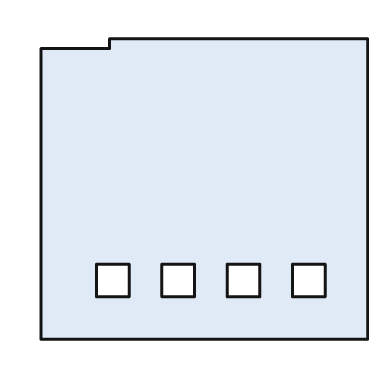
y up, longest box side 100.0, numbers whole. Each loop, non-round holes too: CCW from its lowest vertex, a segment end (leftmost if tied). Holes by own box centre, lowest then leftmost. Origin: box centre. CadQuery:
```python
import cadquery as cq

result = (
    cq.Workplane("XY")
    .moveTo(-50.0, -46.0)
    .lineTo(50.0, -46.0)
    .lineTo(50.0, 46.0)
    .lineTo(-29.0, 46.0)
    .lineTo(-29.0, 43.0)
    .lineTo(-50.0, 43.0)
    .close()
    .moveTo(-33.0, -33.0)
    .lineTo(-23.0, -33.0)
    .lineTo(-23.0, -23.0)
    .lineTo(-33.0, -23.0)
    .close()
    .moveTo(-13.0, -33.0)
    .lineTo(-3.0, -33.0)
    .lineTo(-3.0, -23.0)
    .lineTo(-13.0, -23.0)
    .close()
    .moveTo(7.0, -33.0)
    .lineTo(17.0, -33.0)
    .lineTo(17.0, -23.0)
    .lineTo(7.0, -23.0)
    .close()
    .moveTo(27.0, -33.0)
    .lineTo(37.0, -33.0)
    .lineTo(37.0, -23.0)
    .lineTo(27.0, -23.0)
    .close()
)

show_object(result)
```